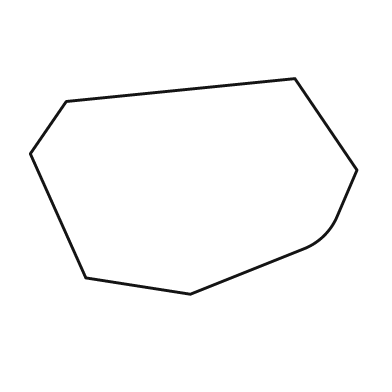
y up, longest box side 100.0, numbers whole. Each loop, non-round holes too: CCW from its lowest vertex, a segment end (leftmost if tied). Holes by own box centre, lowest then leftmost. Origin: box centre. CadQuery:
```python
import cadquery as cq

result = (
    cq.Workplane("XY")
    .moveTo(-1.0, -33.0)
    .lineTo(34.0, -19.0)
    .threePointArc((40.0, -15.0), (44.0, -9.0))
    .lineTo(50.0, 5.0)
    .lineTo(31.0, 33.0)
    .lineTo(-39.0, 26.0)
    .lineTo(-50.0, 10.0)
    .lineTo(-33.0, -28.0)
    .close()
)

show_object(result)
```